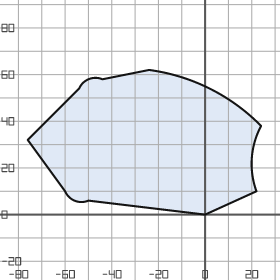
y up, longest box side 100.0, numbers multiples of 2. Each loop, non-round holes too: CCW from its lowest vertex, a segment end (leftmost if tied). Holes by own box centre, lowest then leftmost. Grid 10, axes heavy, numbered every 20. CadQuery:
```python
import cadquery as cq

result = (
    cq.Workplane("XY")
    .moveTo(0.0, 0.0)
    .lineTo(22.0, 10.0)
    .threePointArc((20.0, 24.0), (24.0, 38.0))
    .threePointArc((2.0, 54.0), (-24.0, 62.0))
    .lineTo(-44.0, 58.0)
    .threePointArc((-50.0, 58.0), (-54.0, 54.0))
    .lineTo(-76.0, 32.0)
    .lineTo(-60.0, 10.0)
    .threePointArc((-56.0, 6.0), (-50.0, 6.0))
    .close()
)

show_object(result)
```